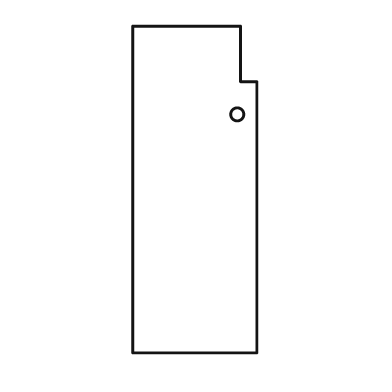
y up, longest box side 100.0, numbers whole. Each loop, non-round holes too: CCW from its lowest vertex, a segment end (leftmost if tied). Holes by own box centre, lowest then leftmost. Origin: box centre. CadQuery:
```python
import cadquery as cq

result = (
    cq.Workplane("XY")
    .moveTo(-19.0, -50.0)
    .lineTo(19.0, -50.0)
    .lineTo(19.0, 33.0)
    .lineTo(14.0, 33.0)
    .lineTo(14.0, 50.0)
    .lineTo(-19.0, 50.0)
    .close()
    .moveTo(13.0, 23.0)
    .circle(2.0)
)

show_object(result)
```